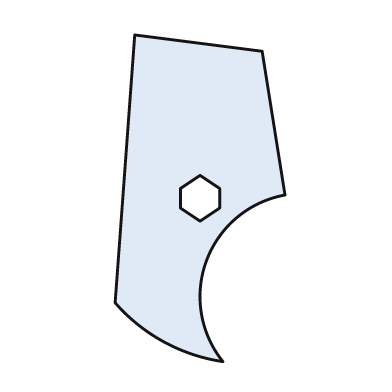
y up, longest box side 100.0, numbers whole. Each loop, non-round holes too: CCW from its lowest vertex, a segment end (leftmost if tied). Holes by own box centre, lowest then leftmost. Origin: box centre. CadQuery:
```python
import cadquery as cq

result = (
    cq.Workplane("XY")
    .moveTo(7.0, -50.0)
    .threePointArc((2.0, -19.0), (26.0, 1.0))
    .lineTo(19.0, 45.0)
    .lineTo(-20.0, 50.0)
    .lineTo(-26.0, -32.0)
    .threePointArc((-11.0, -44.0), (7.0, -50.0))
    .close()
    .moveTo(0.0, -7.0)
    .lineTo(6.0, -3.0)
    .lineTo(6.0, 3.0)
    .lineTo(0.0, 7.0)
    .lineTo(-6.0, 3.0)
    .lineTo(-6.0, -3.0)
    .close()
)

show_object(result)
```